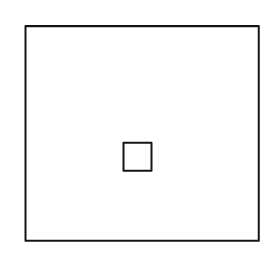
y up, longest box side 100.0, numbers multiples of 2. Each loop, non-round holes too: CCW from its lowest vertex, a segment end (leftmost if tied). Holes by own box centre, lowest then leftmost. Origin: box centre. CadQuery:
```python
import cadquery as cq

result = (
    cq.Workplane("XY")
    .moveTo(-50.0, -46.0)
    .lineTo(50.0, -46.0)
    .lineTo(50.0, 46.0)
    .lineTo(-50.0, 46.0)
    .close()
    .moveTo(-8.0, -16.0)
    .lineTo(4.0, -16.0)
    .lineTo(4.0, -4.0)
    .lineTo(-8.0, -4.0)
    .close()
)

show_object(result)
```